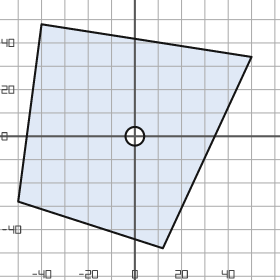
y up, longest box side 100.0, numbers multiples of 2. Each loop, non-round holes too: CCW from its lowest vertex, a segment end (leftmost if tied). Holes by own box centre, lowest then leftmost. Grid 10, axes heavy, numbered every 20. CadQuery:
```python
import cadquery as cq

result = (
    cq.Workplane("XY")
    .moveTo(12.0, -48.0)
    .lineTo(50.0, 34.0)
    .lineTo(-40.0, 48.0)
    .lineTo(-50.0, -28.0)
    .close()
    .moveTo(0.0, 0.0)
    .circle(4.0)
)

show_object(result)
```